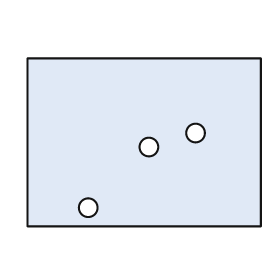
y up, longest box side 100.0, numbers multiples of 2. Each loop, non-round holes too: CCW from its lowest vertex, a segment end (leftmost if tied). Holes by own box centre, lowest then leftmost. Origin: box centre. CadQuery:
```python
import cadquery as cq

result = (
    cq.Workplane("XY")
    .moveTo(-50.0, -36.0)
    .lineTo(50.0, -36.0)
    .lineTo(50.0, 36.0)
    .lineTo(-50.0, 36.0)
    .close()
    .moveTo(-24.0, -28.0)
    .circle(4.0)
    .moveTo(2.0, -2.0)
    .circle(4.0)
    .moveTo(22.0, 4.0)
    .circle(4.0)
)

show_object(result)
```